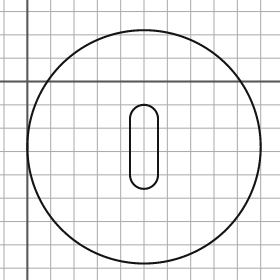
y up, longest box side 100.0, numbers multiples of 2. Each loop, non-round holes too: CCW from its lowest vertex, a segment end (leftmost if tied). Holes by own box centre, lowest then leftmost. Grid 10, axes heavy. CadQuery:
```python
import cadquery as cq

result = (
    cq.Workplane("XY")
    .moveTo(50.0, -28.0)
    .circle(50.0)
    .moveTo(44.0, -40.0)
    .threePointArc((50.0, -46.0), (56.0, -40.0))
    .lineTo(56.0, -16.0)
    .threePointArc((50.0, -10.0), (44.0, -16.0))
    .close()
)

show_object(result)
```